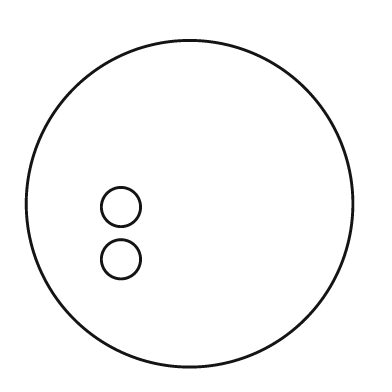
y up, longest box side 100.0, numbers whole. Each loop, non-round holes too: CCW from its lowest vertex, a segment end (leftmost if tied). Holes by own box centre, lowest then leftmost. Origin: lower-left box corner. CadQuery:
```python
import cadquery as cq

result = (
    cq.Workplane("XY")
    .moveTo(50.0, 50.0)
    .circle(50.0)
    .moveTo(29.0, 33.0)
    .circle(6.0)
    .moveTo(29.0, 49.0)
    .circle(6.0)
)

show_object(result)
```